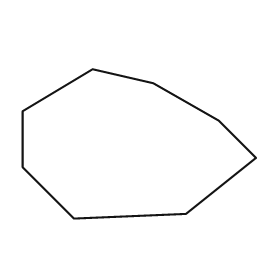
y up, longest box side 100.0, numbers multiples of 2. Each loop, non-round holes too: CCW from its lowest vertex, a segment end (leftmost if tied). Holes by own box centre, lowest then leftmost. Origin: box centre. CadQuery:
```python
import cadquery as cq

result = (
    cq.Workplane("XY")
    .moveTo(-28.0, -32.0)
    .lineTo(20.0, -30.0)
    .lineTo(50.0, -6.0)
    .lineTo(34.0, 10.0)
    .lineTo(6.0, 26.0)
    .lineTo(-20.0, 32.0)
    .lineTo(-50.0, 14.0)
    .lineTo(-50.0, -10.0)
    .close()
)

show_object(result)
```